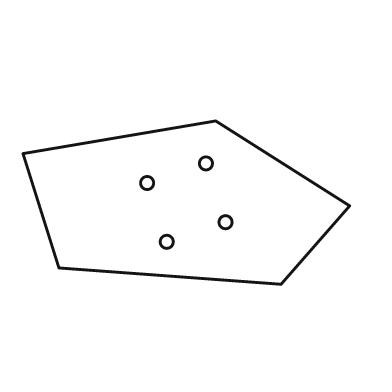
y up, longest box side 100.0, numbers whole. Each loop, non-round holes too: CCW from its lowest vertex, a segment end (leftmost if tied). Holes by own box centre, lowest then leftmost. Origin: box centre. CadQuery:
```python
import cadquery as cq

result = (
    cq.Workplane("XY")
    .moveTo(29.0, -25.0)
    .lineTo(50.0, -1.0)
    .lineTo(9.0, 25.0)
    .lineTo(-50.0, 15.0)
    .lineTo(-39.0, -20.0)
    .close()
    .moveTo(-6.0, -12.0)
    .circle(2.0)
    .moveTo(12.0, -6.0)
    .circle(2.0)
    .moveTo(-12.0, 6.0)
    .circle(2.0)
    .moveTo(6.0, 12.0)
    .circle(2.0)
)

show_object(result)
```